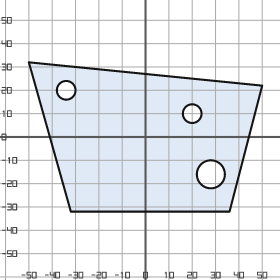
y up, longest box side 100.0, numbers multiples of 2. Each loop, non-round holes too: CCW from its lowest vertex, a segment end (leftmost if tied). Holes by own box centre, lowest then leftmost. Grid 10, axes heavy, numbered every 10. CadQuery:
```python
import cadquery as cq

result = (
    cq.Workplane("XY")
    .moveTo(-32.0, -32.0)
    .lineTo(36.0, -32.0)
    .lineTo(50.0, 22.0)
    .lineTo(-50.0, 32.0)
    .close()
    .moveTo(28.0, -16.0)
    .circle(6.0)
    .moveTo(20.0, 10.0)
    .circle(4.0)
    .moveTo(-34.0, 20.0)
    .circle(4.0)
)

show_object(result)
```